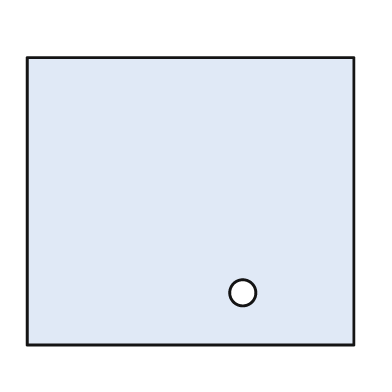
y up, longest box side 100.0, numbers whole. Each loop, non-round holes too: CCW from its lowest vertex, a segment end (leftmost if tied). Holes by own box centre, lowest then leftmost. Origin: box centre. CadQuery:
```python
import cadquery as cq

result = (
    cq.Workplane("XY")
    .moveTo(-50.0, -44.0)
    .lineTo(50.0, -44.0)
    .lineTo(50.0, 44.0)
    .lineTo(-50.0, 44.0)
    .close()
    .moveTo(16.0, -28.0)
    .circle(4.0)
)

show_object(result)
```